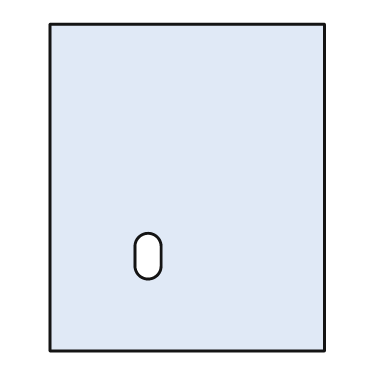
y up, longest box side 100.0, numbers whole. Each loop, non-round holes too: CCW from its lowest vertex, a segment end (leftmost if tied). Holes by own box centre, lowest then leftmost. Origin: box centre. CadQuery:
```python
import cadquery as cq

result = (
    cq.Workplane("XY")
    .moveTo(-42.0, -50.0)
    .lineTo(42.0, -50.0)
    .lineTo(42.0, 50.0)
    .lineTo(-42.0, 50.0)
    .close()
    .moveTo(-16.0, -24.0)
    .threePointArc((-12.0, -28.0), (-8.0, -24.0))
    .lineTo(-8.0, -18.0)
    .threePointArc((-12.0, -14.0), (-16.0, -18.0))
    .close()
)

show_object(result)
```